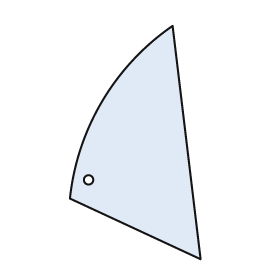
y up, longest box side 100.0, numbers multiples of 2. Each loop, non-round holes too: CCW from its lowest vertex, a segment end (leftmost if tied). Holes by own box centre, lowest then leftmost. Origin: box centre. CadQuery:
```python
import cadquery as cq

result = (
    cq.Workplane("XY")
    .moveTo(28.0, -50.0)
    .lineTo(16.0, 50.0)
    .threePointArc((-14.0, 18.0), (-28.0, -24.0))
    .close()
    .moveTo(-20.0, -16.0)
    .circle(2.0)
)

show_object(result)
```